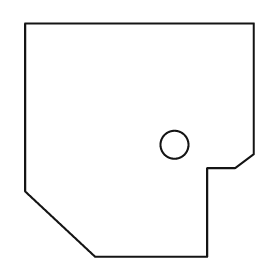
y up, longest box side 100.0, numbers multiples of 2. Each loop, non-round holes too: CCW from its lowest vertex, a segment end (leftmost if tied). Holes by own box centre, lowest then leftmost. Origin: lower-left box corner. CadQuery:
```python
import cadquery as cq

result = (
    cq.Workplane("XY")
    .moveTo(30.0, 0.0)
    .lineTo(78.0, 0.0)
    .lineTo(78.0, 38.0)
    .lineTo(90.0, 38.0)
    .lineTo(98.0, 44.0)
    .lineTo(98.0, 100.0)
    .lineTo(0.0, 100.0)
    .lineTo(0.0, 28.0)
    .close()
    .moveTo(64.0, 48.0)
    .circle(6.0)
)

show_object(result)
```